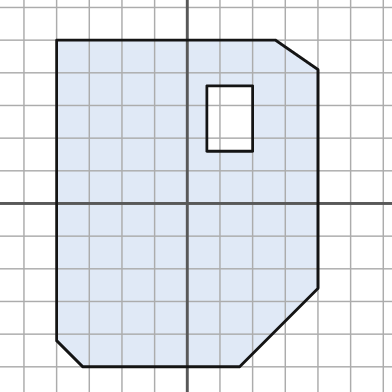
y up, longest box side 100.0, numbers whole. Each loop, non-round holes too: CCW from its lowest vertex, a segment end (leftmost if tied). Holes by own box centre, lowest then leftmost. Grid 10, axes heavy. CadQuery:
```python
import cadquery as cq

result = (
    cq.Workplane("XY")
    .moveTo(-32.0, -50.0)
    .lineTo(16.0, -50.0)
    .lineTo(40.0, -26.0)
    .lineTo(40.0, 41.0)
    .lineTo(27.0, 50.0)
    .lineTo(-40.0, 50.0)
    .lineTo(-40.0, -42.0)
    .close()
    .moveTo(6.0, 16.0)
    .lineTo(20.0, 16.0)
    .lineTo(20.0, 36.0)
    .lineTo(6.0, 36.0)
    .close()
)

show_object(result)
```